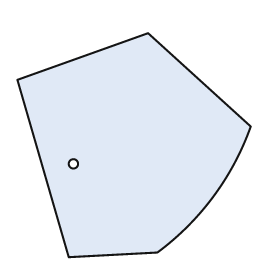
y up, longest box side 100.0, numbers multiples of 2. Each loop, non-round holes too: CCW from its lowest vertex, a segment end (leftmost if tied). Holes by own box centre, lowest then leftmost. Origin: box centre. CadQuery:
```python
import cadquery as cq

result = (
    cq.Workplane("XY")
    .moveTo(-28.0, -48.0)
    .lineTo(10.0, -46.0)
    .threePointArc((34.0, -22.0), (50.0, 8.0))
    .lineTo(6.0, 48.0)
    .lineTo(-50.0, 28.0)
    .close()
    .moveTo(-26.0, -8.0)
    .circle(2.0)
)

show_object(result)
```